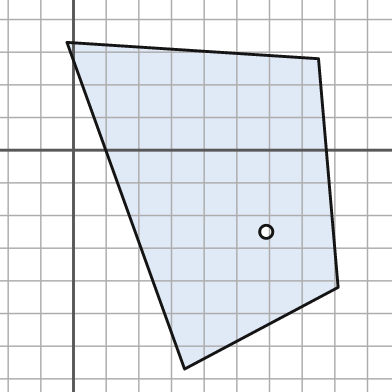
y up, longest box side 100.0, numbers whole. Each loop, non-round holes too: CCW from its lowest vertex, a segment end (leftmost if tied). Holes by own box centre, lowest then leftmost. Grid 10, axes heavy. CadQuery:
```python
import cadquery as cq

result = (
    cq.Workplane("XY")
    .moveTo(34.0, -67.0)
    .lineTo(81.0, -42.0)
    .lineTo(75.0, 28.0)
    .lineTo(-2.0, 33.0)
    .close()
    .moveTo(59.0, -25.0)
    .circle(2.0)
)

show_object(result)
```